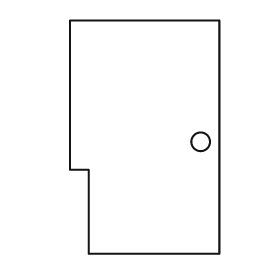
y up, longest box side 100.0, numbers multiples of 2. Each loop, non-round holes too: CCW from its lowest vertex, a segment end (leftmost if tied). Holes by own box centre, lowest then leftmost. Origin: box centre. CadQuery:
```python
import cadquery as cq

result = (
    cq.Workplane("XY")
    .moveTo(-24.0, -50.0)
    .lineTo(32.0, -50.0)
    .lineTo(32.0, 50.0)
    .lineTo(-32.0, 50.0)
    .lineTo(-32.0, -14.0)
    .lineTo(-24.0, -14.0)
    .close()
    .moveTo(24.0, -2.0)
    .circle(4.0)
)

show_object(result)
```